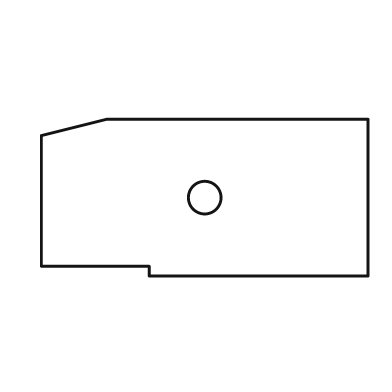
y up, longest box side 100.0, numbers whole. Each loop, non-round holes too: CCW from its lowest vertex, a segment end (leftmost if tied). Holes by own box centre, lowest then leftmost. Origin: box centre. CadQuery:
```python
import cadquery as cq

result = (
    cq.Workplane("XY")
    .moveTo(-17.0, -24.0)
    .lineTo(50.0, -24.0)
    .lineTo(50.0, 24.0)
    .lineTo(-30.0, 24.0)
    .lineTo(-50.0, 19.0)
    .lineTo(-50.0, -21.0)
    .lineTo(-17.0, -21.0)
    .close()
    .moveTo(0.0, 0.0)
    .circle(5.0)
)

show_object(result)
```